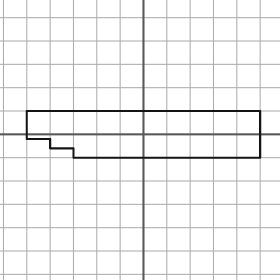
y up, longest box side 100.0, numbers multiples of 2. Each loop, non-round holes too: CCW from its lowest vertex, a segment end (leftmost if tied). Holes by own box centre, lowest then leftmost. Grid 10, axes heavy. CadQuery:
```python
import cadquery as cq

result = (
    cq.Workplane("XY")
    .moveTo(-30.0, -10.0)
    .lineTo(50.0, -10.0)
    .lineTo(50.0, 10.0)
    .lineTo(-50.0, 10.0)
    .lineTo(-50.0, -2.0)
    .lineTo(-40.0, -2.0)
    .lineTo(-40.0, -6.0)
    .lineTo(-30.0, -6.0)
    .close()
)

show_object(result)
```